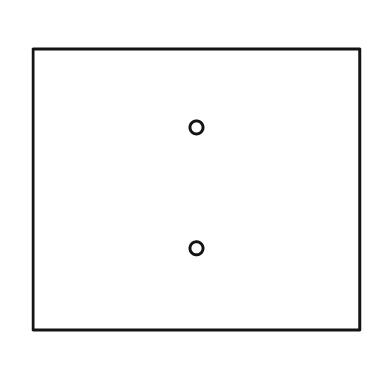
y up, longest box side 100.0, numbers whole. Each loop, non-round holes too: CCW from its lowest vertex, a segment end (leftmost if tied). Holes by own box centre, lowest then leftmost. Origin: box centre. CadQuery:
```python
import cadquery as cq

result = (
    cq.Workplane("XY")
    .moveTo(-50.0, -43.0)
    .lineTo(50.0, -43.0)
    .lineTo(50.0, 43.0)
    .lineTo(-50.0, 43.0)
    .close()
    .moveTo(0.0, -18.0)
    .circle(2.0)
    .moveTo(0.0, 19.0)
    .circle(2.0)
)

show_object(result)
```